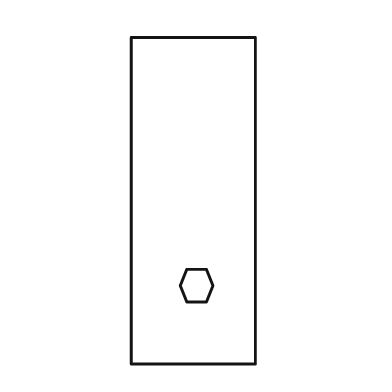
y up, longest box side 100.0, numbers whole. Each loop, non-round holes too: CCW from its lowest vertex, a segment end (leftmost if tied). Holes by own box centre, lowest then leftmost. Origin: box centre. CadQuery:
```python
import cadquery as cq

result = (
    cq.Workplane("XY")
    .moveTo(-19.0, -50.0)
    .lineTo(19.0, -50.0)
    .lineTo(19.0, 50.0)
    .lineTo(-19.0, 50.0)
    .close()
    .moveTo(-2.0, -31.0)
    .lineTo(4.0, -31.0)
    .lineTo(6.0, -26.0)
    .lineTo(4.0, -21.0)
    .lineTo(-2.0, -21.0)
    .lineTo(-4.0, -26.0)
    .close()
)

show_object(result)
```